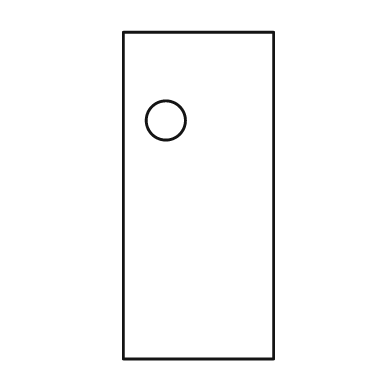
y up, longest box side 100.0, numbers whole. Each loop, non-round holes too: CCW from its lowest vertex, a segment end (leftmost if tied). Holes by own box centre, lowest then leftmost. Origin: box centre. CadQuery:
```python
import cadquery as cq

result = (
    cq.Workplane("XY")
    .moveTo(-23.0, -50.0)
    .lineTo(23.0, -50.0)
    .lineTo(23.0, 50.0)
    .lineTo(-23.0, 50.0)
    .close()
    .moveTo(-10.0, 23.0)
    .circle(6.0)
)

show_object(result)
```